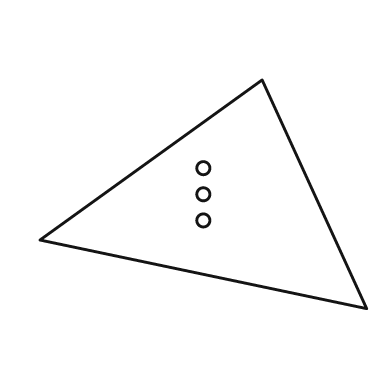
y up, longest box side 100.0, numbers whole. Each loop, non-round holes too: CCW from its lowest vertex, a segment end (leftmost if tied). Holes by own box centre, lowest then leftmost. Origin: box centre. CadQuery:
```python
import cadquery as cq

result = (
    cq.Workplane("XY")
    .moveTo(50.0, -35.0)
    .lineTo(18.0, 35.0)
    .lineTo(-50.0, -14.0)
    .close()
    .moveTo(0.0, -8.0)
    .circle(2.0)
    .moveTo(0.0, 0.0)
    .circle(2.0)
    .moveTo(0.0, 8.0)
    .circle(2.0)
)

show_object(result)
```